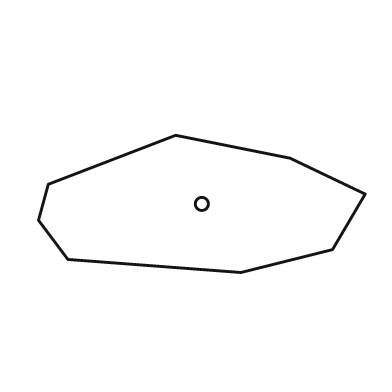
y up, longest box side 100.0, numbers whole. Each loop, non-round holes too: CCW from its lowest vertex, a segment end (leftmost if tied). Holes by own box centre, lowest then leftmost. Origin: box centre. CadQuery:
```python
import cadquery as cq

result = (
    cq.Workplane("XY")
    .moveTo(12.0, -21.0)
    .lineTo(40.0, -14.0)
    .lineTo(50.0, 3.0)
    .lineTo(27.0, 14.0)
    .lineTo(-8.0, 21.0)
    .lineTo(-47.0, 6.0)
    .lineTo(-50.0, -5.0)
    .lineTo(-41.0, -17.0)
    .close()
    .moveTo(0.0, 0.0)
    .circle(2.0)
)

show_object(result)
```